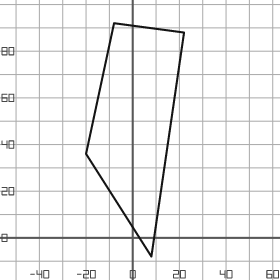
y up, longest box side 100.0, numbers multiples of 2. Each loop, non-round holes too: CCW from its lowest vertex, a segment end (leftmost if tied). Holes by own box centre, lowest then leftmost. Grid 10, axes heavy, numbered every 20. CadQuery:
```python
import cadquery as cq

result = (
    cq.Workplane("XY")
    .moveTo(8.0, -8.0)
    .lineTo(22.0, 88.0)
    .lineTo(-8.0, 92.0)
    .lineTo(-20.0, 36.0)
    .close()
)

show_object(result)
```